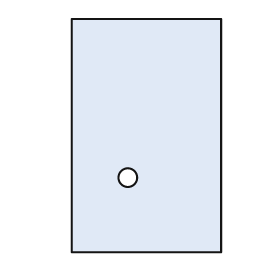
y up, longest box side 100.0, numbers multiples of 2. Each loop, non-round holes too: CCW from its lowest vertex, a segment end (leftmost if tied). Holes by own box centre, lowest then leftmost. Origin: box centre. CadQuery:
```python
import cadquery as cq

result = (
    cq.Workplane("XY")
    .moveTo(-32.0, -50.0)
    .lineTo(32.0, -50.0)
    .lineTo(32.0, 50.0)
    .lineTo(-32.0, 50.0)
    .close()
    .moveTo(-8.0, -18.0)
    .circle(4.0)
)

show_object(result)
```